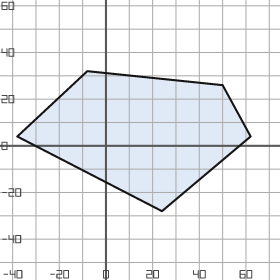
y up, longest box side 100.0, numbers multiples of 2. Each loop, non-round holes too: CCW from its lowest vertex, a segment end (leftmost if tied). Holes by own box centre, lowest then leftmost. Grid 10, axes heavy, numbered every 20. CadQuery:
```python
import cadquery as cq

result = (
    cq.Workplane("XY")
    .moveTo(24.0, -28.0)
    .lineTo(62.0, 4.0)
    .lineTo(50.0, 26.0)
    .lineTo(-8.0, 32.0)
    .lineTo(-38.0, 4.0)
    .close()
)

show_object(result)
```